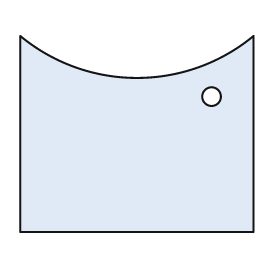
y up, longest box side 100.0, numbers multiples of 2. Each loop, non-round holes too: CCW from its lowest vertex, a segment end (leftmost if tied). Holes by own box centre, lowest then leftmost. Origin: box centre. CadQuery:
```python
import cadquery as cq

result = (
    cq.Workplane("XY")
    .moveTo(-50.0, -42.0)
    .lineTo(50.0, -42.0)
    .lineTo(50.0, 42.0)
    .threePointArc((0.0, 24.0), (-50.0, 42.0))
    .close()
    .moveTo(32.0, 16.0)
    .circle(4.0)
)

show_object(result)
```